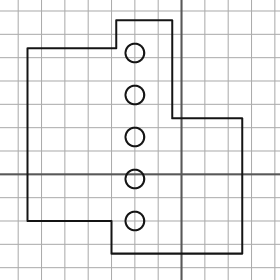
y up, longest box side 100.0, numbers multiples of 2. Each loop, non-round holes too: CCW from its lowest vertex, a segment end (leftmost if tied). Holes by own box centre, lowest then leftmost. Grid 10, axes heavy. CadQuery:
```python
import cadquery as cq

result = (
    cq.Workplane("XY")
    .moveTo(-30.0, -34.0)
    .lineTo(26.0, -34.0)
    .lineTo(26.0, 24.0)
    .lineTo(-4.0, 24.0)
    .lineTo(-4.0, 66.0)
    .lineTo(-28.0, 66.0)
    .lineTo(-28.0, 54.0)
    .lineTo(-66.0, 54.0)
    .lineTo(-66.0, -20.0)
    .lineTo(-30.0, -20.0)
    .close()
    .moveTo(-20.0, -20.0)
    .circle(4.0)
    .moveTo(-20.0, -2.0)
    .circle(4.0)
    .moveTo(-20.0, 16.0)
    .circle(4.0)
    .moveTo(-20.0, 34.0)
    .circle(4.0)
    .moveTo(-20.0, 52.0)
    .circle(4.0)
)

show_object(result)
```